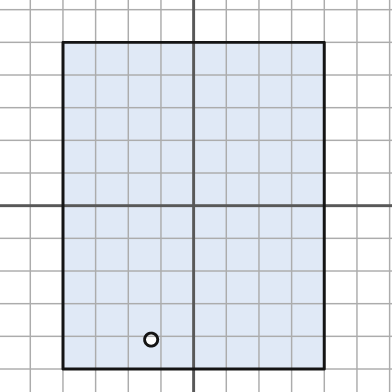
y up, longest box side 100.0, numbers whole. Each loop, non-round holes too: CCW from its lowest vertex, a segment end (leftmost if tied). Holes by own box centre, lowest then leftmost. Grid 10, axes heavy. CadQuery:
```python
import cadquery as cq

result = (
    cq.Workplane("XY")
    .moveTo(-40.0, -50.0)
    .lineTo(40.0, -50.0)
    .lineTo(40.0, 50.0)
    .lineTo(-40.0, 50.0)
    .close()
    .moveTo(-13.0, -41.0)
    .circle(2.0)
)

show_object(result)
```